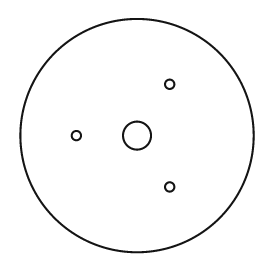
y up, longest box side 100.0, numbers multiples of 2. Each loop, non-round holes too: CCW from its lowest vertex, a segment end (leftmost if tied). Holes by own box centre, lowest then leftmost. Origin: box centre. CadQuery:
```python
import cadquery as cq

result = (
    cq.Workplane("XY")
    .moveTo(0.0, 0.0)
    .circle(50.0)
    .moveTo(14.0, -22.0)
    .circle(2.0)
    .moveTo(-26.0, 0.0)
    .circle(2.0)
    .moveTo(0.0, 0.0)
    .circle(6.0)
    .moveTo(14.0, 22.0)
    .circle(2.0)
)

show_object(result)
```